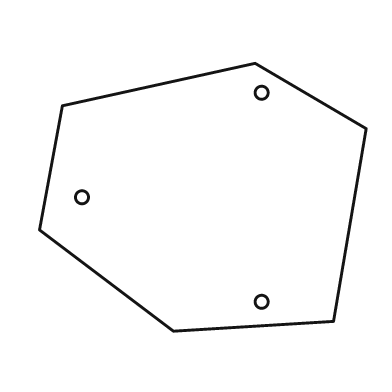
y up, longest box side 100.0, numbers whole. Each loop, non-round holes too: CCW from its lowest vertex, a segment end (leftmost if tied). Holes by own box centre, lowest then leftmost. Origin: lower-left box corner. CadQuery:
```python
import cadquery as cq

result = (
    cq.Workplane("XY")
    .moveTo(41.0, 0.0)
    .lineTo(90.0, 3.0)
    .lineTo(100.0, 62.0)
    .lineTo(66.0, 82.0)
    .lineTo(7.0, 69.0)
    .lineTo(0.0, 31.0)
    .close()
    .moveTo(68.0, 9.0)
    .circle(2.0)
    .moveTo(13.0, 41.0)
    .circle(2.0)
    .moveTo(68.0, 73.0)
    .circle(2.0)
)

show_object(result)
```